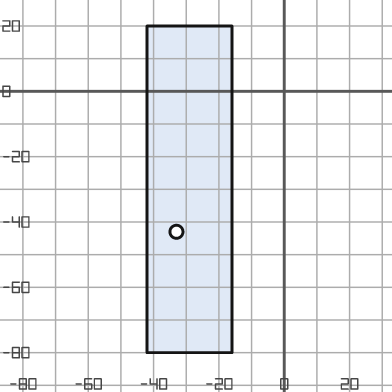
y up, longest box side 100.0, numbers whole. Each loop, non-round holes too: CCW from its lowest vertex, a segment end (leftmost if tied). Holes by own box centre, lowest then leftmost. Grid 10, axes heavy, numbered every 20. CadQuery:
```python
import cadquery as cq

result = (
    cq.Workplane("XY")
    .moveTo(-42.0, -80.0)
    .lineTo(-16.0, -80.0)
    .lineTo(-16.0, 20.0)
    .lineTo(-42.0, 20.0)
    .close()
    .moveTo(-33.0, -43.0)
    .circle(2.0)
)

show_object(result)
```